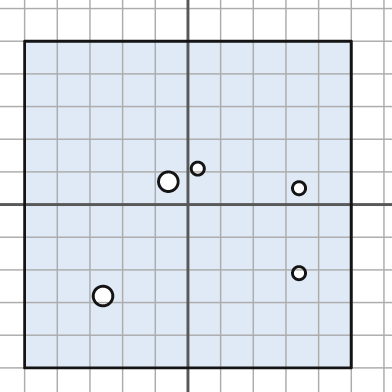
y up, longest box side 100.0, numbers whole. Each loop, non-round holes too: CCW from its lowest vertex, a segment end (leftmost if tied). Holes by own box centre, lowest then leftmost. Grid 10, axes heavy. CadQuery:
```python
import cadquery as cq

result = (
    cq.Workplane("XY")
    .moveTo(-50.0, -50.0)
    .lineTo(50.0, -50.0)
    .lineTo(50.0, 50.0)
    .lineTo(-50.0, 50.0)
    .close()
    .moveTo(-26.0, -28.0)
    .circle(3.0)
    .moveTo(34.0, -21.0)
    .circle(2.0)
    .moveTo(34.0, 5.0)
    .circle(2.0)
    .moveTo(-6.0, 7.0)
    .circle(3.0)
    .moveTo(3.0, 11.0)
    .circle(2.0)
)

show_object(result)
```